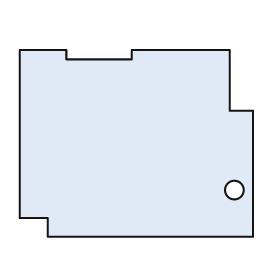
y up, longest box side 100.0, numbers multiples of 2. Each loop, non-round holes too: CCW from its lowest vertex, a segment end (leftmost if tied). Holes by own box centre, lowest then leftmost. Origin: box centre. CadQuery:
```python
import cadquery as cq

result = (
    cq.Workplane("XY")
    .moveTo(-38.0, -40.0)
    .lineTo(50.0, -40.0)
    .lineTo(50.0, 14.0)
    .lineTo(40.0, 14.0)
    .lineTo(40.0, 40.0)
    .lineTo(-2.0, 40.0)
    .lineTo(-2.0, 36.0)
    .lineTo(-30.0, 36.0)
    .lineTo(-30.0, 40.0)
    .lineTo(-50.0, 40.0)
    .lineTo(-50.0, -32.0)
    .lineTo(-38.0, -32.0)
    .close()
    .moveTo(42.0, -20.0)
    .circle(4.0)
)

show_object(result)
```